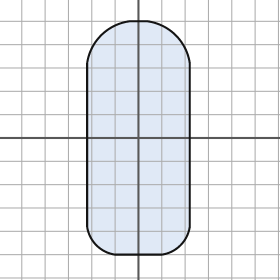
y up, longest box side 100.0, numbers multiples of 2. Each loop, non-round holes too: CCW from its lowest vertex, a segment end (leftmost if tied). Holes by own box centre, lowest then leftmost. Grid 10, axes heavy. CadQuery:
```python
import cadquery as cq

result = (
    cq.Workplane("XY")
    .moveTo(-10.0, -50.0)
    .lineTo(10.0, -50.0)
    .threePointArc((18.0, -46.0), (22.0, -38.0))
    .lineTo(22.0, 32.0)
    .threePointArc((16.0, 44.0), (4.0, 50.0))
    .lineTo(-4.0, 50.0)
    .threePointArc((-16.0, 44.0), (-22.0, 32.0))
    .lineTo(-22.0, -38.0)
    .threePointArc((-18.0, -46.0), (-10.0, -50.0))
    .close()
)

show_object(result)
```